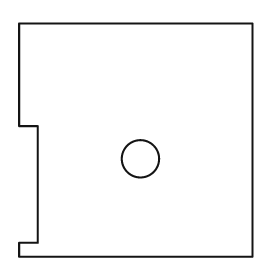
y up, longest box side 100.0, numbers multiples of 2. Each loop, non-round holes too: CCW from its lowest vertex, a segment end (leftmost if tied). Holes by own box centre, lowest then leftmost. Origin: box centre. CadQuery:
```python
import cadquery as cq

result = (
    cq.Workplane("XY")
    .moveTo(-50.0, -50.0)
    .lineTo(50.0, -50.0)
    .lineTo(50.0, 50.0)
    .lineTo(-50.0, 50.0)
    .lineTo(-50.0, 6.0)
    .lineTo(-42.0, 6.0)
    .lineTo(-42.0, -44.0)
    .lineTo(-50.0, -44.0)
    .close()
    .moveTo(2.0, -8.0)
    .circle(8.0)
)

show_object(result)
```